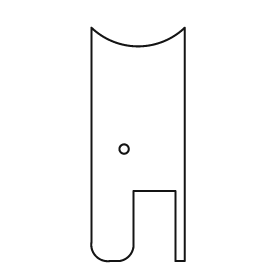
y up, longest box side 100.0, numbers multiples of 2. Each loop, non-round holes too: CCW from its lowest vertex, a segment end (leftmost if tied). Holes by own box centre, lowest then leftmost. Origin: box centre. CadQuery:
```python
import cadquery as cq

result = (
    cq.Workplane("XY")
    .moveTo(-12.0, -50.0)
    .lineTo(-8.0, -50.0)
    .threePointArc((-4.0, -48.0), (-2.0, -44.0))
    .lineTo(-2.0, -20.0)
    .lineTo(16.0, -20.0)
    .lineTo(16.0, -50.0)
    .lineTo(20.0, -50.0)
    .lineTo(20.0, 50.0)
    .threePointArc((0.0, 42.0), (-20.0, 50.0))
    .lineTo(-20.0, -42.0)
    .threePointArc((-18.0, -48.0), (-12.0, -50.0))
    .close()
    .moveTo(-6.0, -2.0)
    .circle(2.0)
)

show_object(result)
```